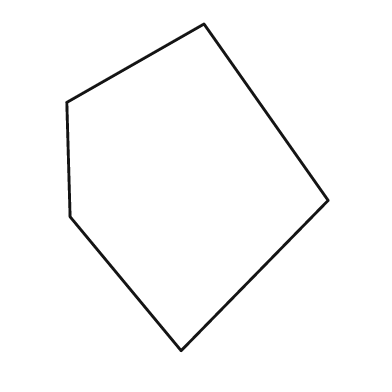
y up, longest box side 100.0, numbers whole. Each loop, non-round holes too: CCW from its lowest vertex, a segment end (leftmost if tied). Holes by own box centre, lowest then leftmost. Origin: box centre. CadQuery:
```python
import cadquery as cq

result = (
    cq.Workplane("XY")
    .moveTo(-5.0, -50.0)
    .lineTo(40.0, -4.0)
    .lineTo(2.0, 50.0)
    .lineTo(-40.0, 26.0)
    .lineTo(-39.0, -9.0)
    .close()
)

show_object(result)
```